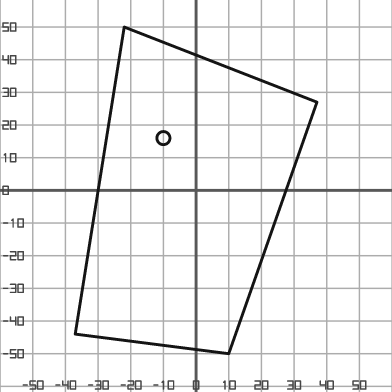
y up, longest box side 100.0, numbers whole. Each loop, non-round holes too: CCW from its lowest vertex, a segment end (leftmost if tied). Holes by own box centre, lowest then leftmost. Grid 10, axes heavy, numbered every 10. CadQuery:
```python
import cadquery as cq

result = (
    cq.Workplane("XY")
    .moveTo(10.0, -50.0)
    .lineTo(37.0, 27.0)
    .lineTo(-22.0, 50.0)
    .lineTo(-37.0, -44.0)
    .close()
    .moveTo(-10.0, 16.0)
    .circle(2.0)
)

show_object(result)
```